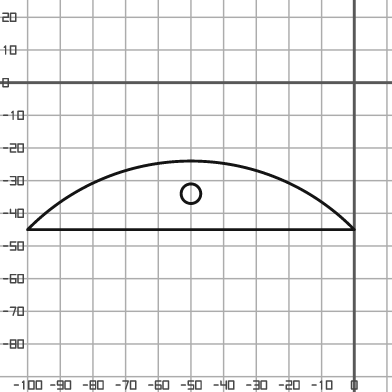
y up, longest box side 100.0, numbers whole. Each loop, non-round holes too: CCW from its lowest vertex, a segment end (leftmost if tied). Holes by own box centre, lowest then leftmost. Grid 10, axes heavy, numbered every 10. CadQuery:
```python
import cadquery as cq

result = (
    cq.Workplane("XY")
    .moveTo(-100.0, -45.0)
    .lineTo(0.0, -45.0)
    .threePointArc((-50.0, -24.0), (-100.0, -45.0))
    .close()
    .moveTo(-50.0, -34.0)
    .circle(3.0)
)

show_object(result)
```